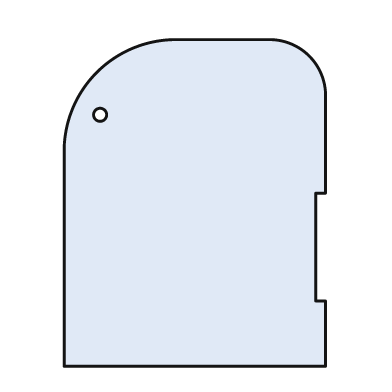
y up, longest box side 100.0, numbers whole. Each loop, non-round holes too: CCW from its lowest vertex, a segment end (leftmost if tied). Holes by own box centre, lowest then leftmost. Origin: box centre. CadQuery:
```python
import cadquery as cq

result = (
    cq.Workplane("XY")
    .moveTo(-40.0, -50.0)
    .lineTo(40.0, -50.0)
    .lineTo(40.0, -30.0)
    .lineTo(37.0, -30.0)
    .lineTo(37.0, 3.0)
    .lineTo(40.0, 3.0)
    .lineTo(40.0, 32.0)
    .threePointArc((35.0, 45.0), (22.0, 50.0))
    .lineTo(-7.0, 50.0)
    .threePointArc((-30.0, 40.0), (-40.0, 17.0))
    .close()
    .moveTo(-29.0, 27.0)
    .circle(2.0)
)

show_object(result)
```